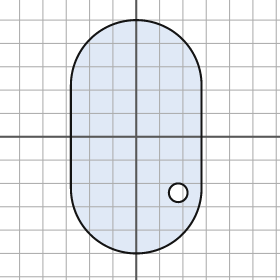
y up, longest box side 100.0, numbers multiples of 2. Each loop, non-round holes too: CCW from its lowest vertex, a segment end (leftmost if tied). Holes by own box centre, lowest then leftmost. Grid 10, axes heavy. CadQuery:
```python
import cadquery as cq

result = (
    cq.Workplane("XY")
    .moveTo(-28.0, -22.0)
    .threePointArc((0.0, -50.0), (28.0, -22.0))
    .lineTo(28.0, 22.0)
    .threePointArc((0.0, 50.0), (-28.0, 22.0))
    .close()
    .moveTo(18.0, -24.0)
    .circle(4.0)
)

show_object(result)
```